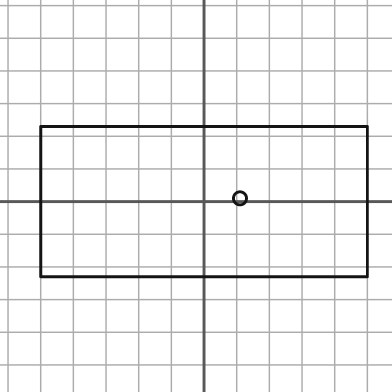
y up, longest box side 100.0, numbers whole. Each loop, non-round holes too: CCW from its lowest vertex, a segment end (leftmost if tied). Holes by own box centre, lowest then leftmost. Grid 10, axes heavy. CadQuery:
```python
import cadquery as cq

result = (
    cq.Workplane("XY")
    .moveTo(-50.0, -23.0)
    .lineTo(50.0, -23.0)
    .lineTo(50.0, 23.0)
    .lineTo(-50.0, 23.0)
    .close()
    .moveTo(11.0, 1.0)
    .circle(2.0)
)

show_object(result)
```